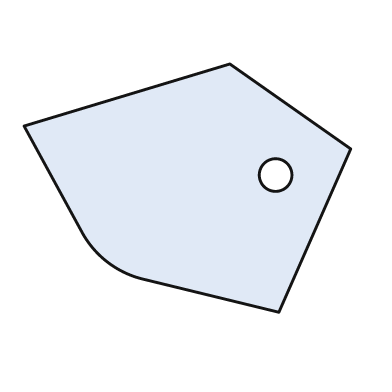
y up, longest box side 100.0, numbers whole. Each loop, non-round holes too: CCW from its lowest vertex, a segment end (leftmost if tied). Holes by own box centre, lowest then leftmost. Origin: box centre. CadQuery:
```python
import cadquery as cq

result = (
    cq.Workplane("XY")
    .moveTo(28.0, -38.0)
    .lineTo(50.0, 12.0)
    .lineTo(13.0, 38.0)
    .lineTo(-50.0, 19.0)
    .lineTo(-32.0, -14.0)
    .threePointArc((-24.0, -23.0), (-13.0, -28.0))
    .close()
    .moveTo(27.0, 4.0)
    .circle(5.0)
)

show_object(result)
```